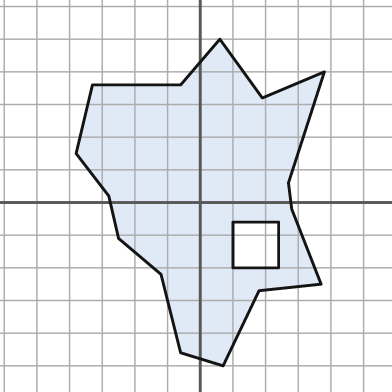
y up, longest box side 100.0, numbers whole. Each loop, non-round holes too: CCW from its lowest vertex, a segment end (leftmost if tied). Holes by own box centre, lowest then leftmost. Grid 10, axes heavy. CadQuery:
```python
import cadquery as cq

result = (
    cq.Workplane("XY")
    .moveTo(7.0, -50.0)
    .lineTo(18.0, -27.0)
    .lineTo(37.0, -25.0)
    .lineTo(28.0, -2.0)
    .lineTo(27.0, 6.0)
    .lineTo(38.0, 40.0)
    .lineTo(19.0, 32.0)
    .lineTo(6.0, 50.0)
    .lineTo(-6.0, 36.0)
    .lineTo(-33.0, 36.0)
    .lineTo(-38.0, 15.0)
    .lineTo(-28.0, 2.0)
    .lineTo(-25.0, -11.0)
    .lineTo(-12.0, -22.0)
    .lineTo(-6.0, -46.0)
    .close()
    .moveTo(10.0, -20.0)
    .lineTo(24.0, -20.0)
    .lineTo(24.0, -6.0)
    .lineTo(10.0, -6.0)
    .close()
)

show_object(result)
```